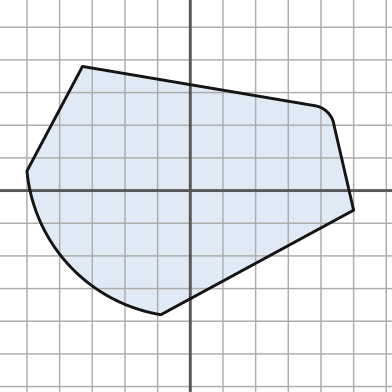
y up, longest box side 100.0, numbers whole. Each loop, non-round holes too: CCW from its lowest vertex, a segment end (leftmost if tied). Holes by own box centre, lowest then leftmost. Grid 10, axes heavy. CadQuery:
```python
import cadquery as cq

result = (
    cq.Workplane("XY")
    .moveTo(-9.0, -38.0)
    .lineTo(50.0, -6.0)
    .lineTo(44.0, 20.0)
    .threePointArc((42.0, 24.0), (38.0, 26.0))
    .lineTo(-33.0, 38.0)
    .lineTo(-50.0, 6.0)
    .threePointArc((-37.0, -23.0), (-9.0, -38.0))
    .close()
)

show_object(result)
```